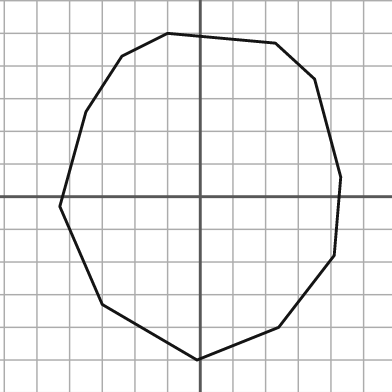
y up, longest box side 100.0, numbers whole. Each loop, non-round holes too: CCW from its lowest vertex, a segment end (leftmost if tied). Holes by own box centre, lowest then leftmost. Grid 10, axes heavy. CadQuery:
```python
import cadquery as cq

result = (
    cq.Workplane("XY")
    .moveTo(-1.0, -50.0)
    .lineTo(24.0, -40.0)
    .lineTo(41.0, -18.0)
    .lineTo(43.0, 6.0)
    .lineTo(35.0, 36.0)
    .lineTo(23.0, 47.0)
    .lineTo(-10.0, 50.0)
    .lineTo(-24.0, 43.0)
    .lineTo(-35.0, 26.0)
    .lineTo(-43.0, -3.0)
    .lineTo(-30.0, -33.0)
    .close()
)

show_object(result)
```